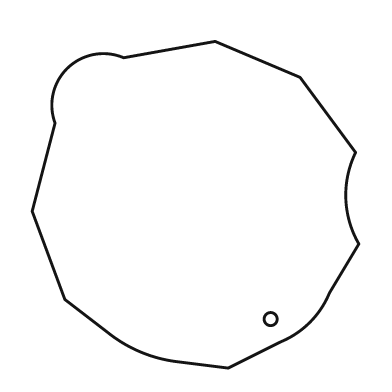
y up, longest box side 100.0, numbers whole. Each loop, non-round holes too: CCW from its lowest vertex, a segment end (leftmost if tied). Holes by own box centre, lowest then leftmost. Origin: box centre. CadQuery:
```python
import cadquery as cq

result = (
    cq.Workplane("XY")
    .moveTo(10.0, -50.0)
    .lineTo(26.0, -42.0)
    .threePointArc((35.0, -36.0), (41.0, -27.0))
    .lineTo(50.0, -12.0)
    .threePointArc((46.0, 2.0), (49.0, 16.0))
    .lineTo(32.0, 39.0)
    .lineTo(6.0, 50.0)
    .lineTo(-22.0, 45.0)
    .threePointArc((-39.0, 42.0), (-43.0, 25.0))
    .lineTo(-50.0, -2.0)
    .lineTo(-40.0, -29.0)
    .lineTo(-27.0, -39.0)
    .threePointArc((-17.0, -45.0), (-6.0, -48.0))
    .close()
    .moveTo(23.0, -35.0)
    .circle(2.0)
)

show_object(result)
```